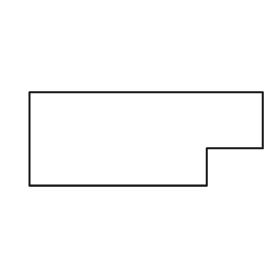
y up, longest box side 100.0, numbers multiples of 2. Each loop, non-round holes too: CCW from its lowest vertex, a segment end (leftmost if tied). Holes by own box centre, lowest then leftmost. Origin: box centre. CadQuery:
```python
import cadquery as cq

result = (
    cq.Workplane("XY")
    .moveTo(-50.0, -20.0)
    .lineTo(26.0, -20.0)
    .lineTo(26.0, -4.0)
    .lineTo(50.0, -4.0)
    .lineTo(50.0, 20.0)
    .lineTo(-50.0, 20.0)
    .close()
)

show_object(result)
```